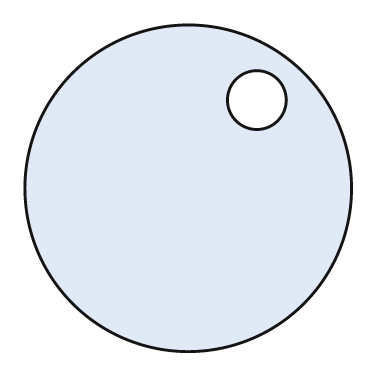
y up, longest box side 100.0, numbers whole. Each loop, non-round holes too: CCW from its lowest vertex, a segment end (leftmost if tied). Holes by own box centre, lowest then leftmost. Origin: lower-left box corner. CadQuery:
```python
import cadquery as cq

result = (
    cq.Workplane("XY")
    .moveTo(50.0, 50.0)
    .circle(50.0)
    .moveTo(71.0, 77.0)
    .circle(9.0)
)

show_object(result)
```